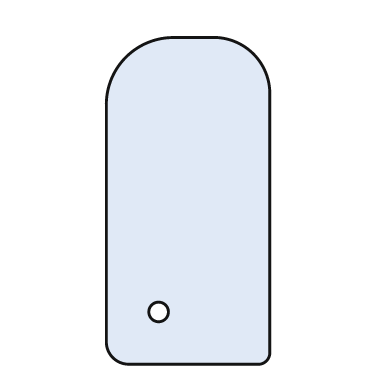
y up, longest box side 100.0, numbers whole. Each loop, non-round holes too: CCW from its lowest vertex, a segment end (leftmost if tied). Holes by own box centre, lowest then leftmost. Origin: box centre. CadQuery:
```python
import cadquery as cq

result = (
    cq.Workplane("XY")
    .moveTo(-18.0, -50.0)
    .lineTo(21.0, -50.0)
    .threePointArc((24.0, -49.0), (25.0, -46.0))
    .lineTo(25.0, 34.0)
    .threePointArc((20.0, 45.0), (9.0, 50.0))
    .lineTo(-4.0, 50.0)
    .threePointArc((-19.0, 44.0), (-25.0, 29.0))
    .lineTo(-25.0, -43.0)
    .threePointArc((-23.0, -48.0), (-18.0, -50.0))
    .close()
    .moveTo(-9.0, -34.0)
    .circle(3.0)
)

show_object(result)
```